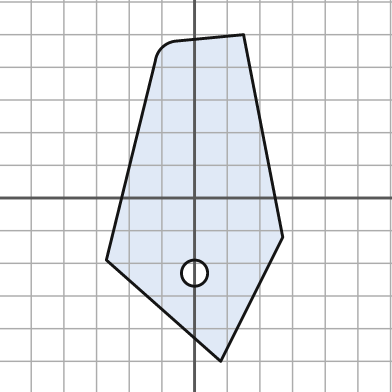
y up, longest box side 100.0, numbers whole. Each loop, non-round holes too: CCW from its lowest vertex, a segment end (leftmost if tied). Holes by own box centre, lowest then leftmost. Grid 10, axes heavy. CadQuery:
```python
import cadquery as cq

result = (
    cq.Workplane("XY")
    .moveTo(8.0, -50.0)
    .lineTo(27.0, -12.0)
    .lineTo(15.0, 50.0)
    .lineTo(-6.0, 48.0)
    .threePointArc((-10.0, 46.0), (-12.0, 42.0))
    .lineTo(-27.0, -19.0)
    .close()
    .moveTo(0.0, -23.0)
    .circle(4.0)
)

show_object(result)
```